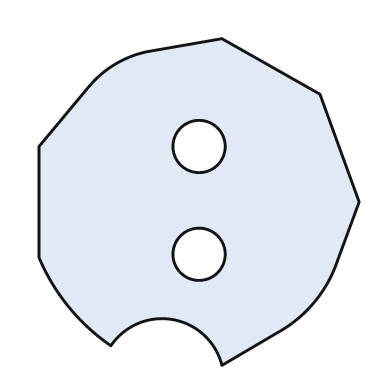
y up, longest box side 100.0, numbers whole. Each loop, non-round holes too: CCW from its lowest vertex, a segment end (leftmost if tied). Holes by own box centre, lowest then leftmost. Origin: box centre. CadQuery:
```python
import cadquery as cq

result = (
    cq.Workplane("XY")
    .moveTo(7.0, -50.0)
    .lineTo(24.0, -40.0)
    .threePointArc((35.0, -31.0), (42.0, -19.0))
    .lineTo(49.0, 0.0)
    .lineTo(37.0, 33.0)
    .lineTo(7.0, 50.0)
    .lineTo(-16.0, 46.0)
    .threePointArc((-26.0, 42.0), (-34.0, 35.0))
    .lineTo(-49.0, 17.0)
    .lineTo(-49.0, -17.0)
    .threePointArc((-40.0, -32.0), (-27.0, -44.0))
    .threePointArc((-8.0, -36.0), (7.0, -50.0))
    .close()
    .moveTo(0.0, -16.0)
    .circle(8.0)
    .moveTo(0.0, 17.0)
    .circle(8.0)
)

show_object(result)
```